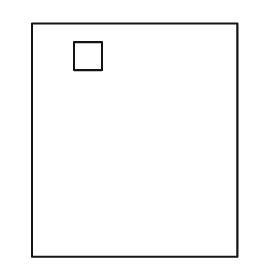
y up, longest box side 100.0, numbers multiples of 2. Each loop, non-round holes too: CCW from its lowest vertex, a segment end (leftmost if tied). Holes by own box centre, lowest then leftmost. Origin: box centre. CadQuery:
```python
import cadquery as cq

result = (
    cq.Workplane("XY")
    .moveTo(-44.0, -50.0)
    .lineTo(44.0, -50.0)
    .lineTo(44.0, 50.0)
    .lineTo(-44.0, 50.0)
    .close()
    .moveTo(-26.0, 30.0)
    .lineTo(-14.0, 30.0)
    .lineTo(-14.0, 42.0)
    .lineTo(-26.0, 42.0)
    .close()
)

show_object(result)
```